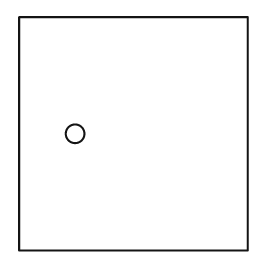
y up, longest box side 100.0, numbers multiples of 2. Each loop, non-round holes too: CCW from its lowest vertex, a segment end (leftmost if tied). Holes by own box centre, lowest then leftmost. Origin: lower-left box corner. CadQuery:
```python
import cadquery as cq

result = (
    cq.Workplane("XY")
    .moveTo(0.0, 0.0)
    .lineTo(98.0, 0.0)
    .lineTo(98.0, 100.0)
    .lineTo(0.0, 100.0)
    .close()
    .moveTo(24.0, 50.0)
    .circle(4.0)
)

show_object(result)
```